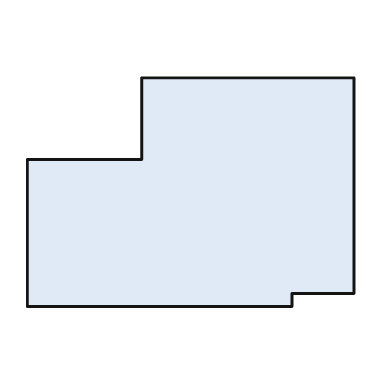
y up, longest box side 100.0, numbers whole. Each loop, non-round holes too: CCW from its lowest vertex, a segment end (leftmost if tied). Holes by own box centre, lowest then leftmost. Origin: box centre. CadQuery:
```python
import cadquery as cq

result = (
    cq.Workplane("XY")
    .moveTo(-50.0, -35.0)
    .lineTo(31.0, -35.0)
    .lineTo(31.0, -31.0)
    .lineTo(50.0, -31.0)
    .lineTo(50.0, 35.0)
    .lineTo(-15.0, 35.0)
    .lineTo(-15.0, 10.0)
    .lineTo(-50.0, 10.0)
    .close()
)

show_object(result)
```